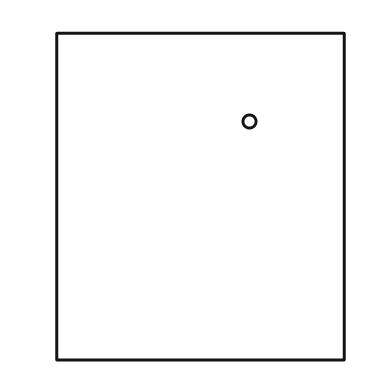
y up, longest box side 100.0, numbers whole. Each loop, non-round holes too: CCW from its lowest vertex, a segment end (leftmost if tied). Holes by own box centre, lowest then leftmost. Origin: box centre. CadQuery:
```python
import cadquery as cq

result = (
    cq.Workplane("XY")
    .moveTo(-44.0, -50.0)
    .lineTo(44.0, -50.0)
    .lineTo(44.0, 50.0)
    .lineTo(-44.0, 50.0)
    .close()
    .moveTo(15.0, 23.0)
    .circle(2.0)
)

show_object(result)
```